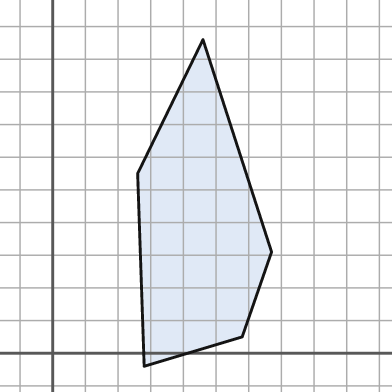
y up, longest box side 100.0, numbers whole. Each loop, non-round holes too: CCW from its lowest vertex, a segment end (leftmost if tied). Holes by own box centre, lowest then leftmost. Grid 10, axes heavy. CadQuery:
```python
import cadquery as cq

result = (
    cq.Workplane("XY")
    .moveTo(28.0, -4.0)
    .lineTo(58.0, 5.0)
    .lineTo(67.0, 31.0)
    .lineTo(46.0, 96.0)
    .lineTo(26.0, 55.0)
    .close()
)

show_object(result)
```